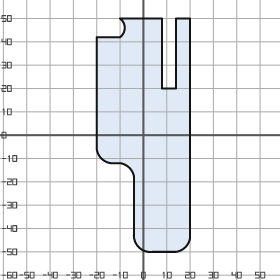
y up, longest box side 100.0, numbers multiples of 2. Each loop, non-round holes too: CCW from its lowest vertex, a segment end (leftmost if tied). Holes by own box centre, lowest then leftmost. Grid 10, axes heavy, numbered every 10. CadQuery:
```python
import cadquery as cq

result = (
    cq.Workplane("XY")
    .moveTo(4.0, -50.0)
    .lineTo(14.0, -50.0)
    .threePointArc((18.0, -48.0), (20.0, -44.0))
    .lineTo(20.0, 50.0)
    .lineTo(14.0, 50.0)
    .lineTo(14.0, 20.0)
    .lineTo(8.0, 20.0)
    .lineTo(8.0, 50.0)
    .lineTo(-10.0, 50.0)
    .threePointArc((-8.0, 46.0), (-10.0, 42.0))
    .lineTo(-20.0, 42.0)
    .lineTo(-20.0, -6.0)
    .threePointArc((-18.0, -10.0), (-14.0, -12.0))
    .lineTo(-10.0, -12.0)
    .threePointArc((-6.0, -14.0), (-4.0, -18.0))
    .lineTo(-4.0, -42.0)
    .threePointArc((-2.0, -48.0), (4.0, -50.0))
    .close()
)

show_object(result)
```